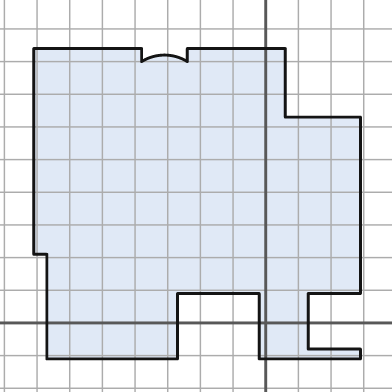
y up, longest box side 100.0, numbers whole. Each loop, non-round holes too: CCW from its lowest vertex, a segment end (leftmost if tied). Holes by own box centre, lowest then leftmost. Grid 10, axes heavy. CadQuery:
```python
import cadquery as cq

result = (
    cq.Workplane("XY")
    .moveTo(-67.0, -11.0)
    .lineTo(-27.0, -11.0)
    .lineTo(-27.0, 9.0)
    .lineTo(-2.0, 9.0)
    .lineTo(-2.0, -11.0)
    .lineTo(29.0, -11.0)
    .lineTo(29.0, -8.0)
    .lineTo(13.0, -8.0)
    .lineTo(13.0, 9.0)
    .lineTo(29.0, 9.0)
    .lineTo(29.0, 63.0)
    .lineTo(6.0, 63.0)
    .lineTo(6.0, 84.0)
    .lineTo(-24.0, 84.0)
    .lineTo(-24.0, 80.0)
    .threePointArc((-31.0, 82.0), (-38.0, 80.0))
    .lineTo(-38.0, 84.0)
    .lineTo(-71.0, 84.0)
    .lineTo(-71.0, 21.0)
    .lineTo(-67.0, 21.0)
    .close()
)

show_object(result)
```